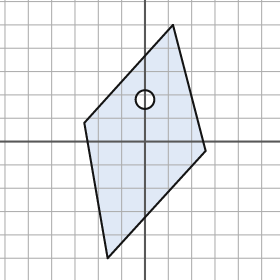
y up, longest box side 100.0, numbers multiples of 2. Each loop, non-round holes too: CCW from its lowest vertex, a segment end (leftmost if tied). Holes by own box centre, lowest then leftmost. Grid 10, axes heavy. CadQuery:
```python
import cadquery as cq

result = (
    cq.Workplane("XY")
    .moveTo(-16.0, -50.0)
    .lineTo(26.0, -4.0)
    .lineTo(12.0, 50.0)
    .lineTo(-26.0, 8.0)
    .close()
    .moveTo(0.0, 18.0)
    .circle(4.0)
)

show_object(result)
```